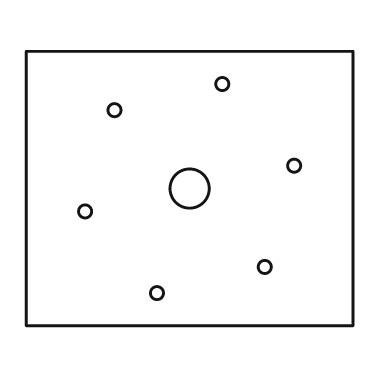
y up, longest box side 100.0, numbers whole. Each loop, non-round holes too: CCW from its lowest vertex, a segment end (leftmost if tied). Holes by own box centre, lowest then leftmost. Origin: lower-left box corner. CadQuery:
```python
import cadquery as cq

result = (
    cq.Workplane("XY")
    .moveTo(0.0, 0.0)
    .lineTo(100.0, 0.0)
    .lineTo(100.0, 84.0)
    .lineTo(0.0, 84.0)
    .close()
    .moveTo(40.0, 10.0)
    .circle(2.0)
    .moveTo(73.0, 18.0)
    .circle(2.0)
    .moveTo(18.0, 35.0)
    .circle(2.0)
    .moveTo(50.0, 42.0)
    .circle(6.0)
    .moveTo(82.0, 49.0)
    .circle(2.0)
    .moveTo(27.0, 66.0)
    .circle(2.0)
    .moveTo(60.0, 74.0)
    .circle(2.0)
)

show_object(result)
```